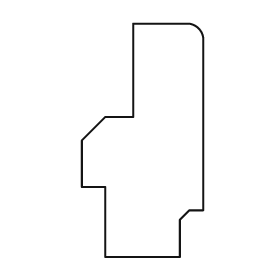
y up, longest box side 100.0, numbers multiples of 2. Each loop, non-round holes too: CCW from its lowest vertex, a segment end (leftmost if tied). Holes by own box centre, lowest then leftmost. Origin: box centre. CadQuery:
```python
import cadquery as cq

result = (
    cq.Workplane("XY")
    .moveTo(-16.0, -50.0)
    .lineTo(16.0, -50.0)
    .lineTo(16.0, -34.0)
    .lineTo(20.0, -30.0)
    .lineTo(26.0, -30.0)
    .lineTo(26.0, 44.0)
    .threePointArc((24.0, 48.0), (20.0, 50.0))
    .lineTo(-4.0, 50.0)
    .lineTo(-4.0, 10.0)
    .lineTo(-16.0, 10.0)
    .lineTo(-26.0, 0.0)
    .lineTo(-26.0, -20.0)
    .lineTo(-16.0, -20.0)
    .close()
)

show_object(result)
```